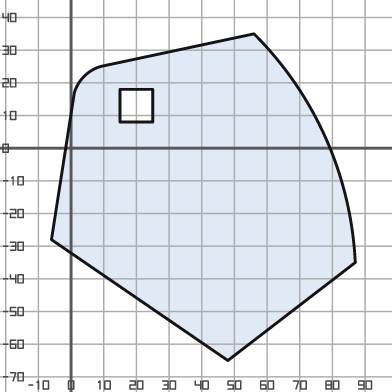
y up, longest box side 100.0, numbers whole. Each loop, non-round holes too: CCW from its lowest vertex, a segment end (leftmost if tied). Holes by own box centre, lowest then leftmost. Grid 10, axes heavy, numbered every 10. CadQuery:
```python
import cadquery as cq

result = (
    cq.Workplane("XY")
    .moveTo(48.0, -65.0)
    .lineTo(87.0, -35.0)
    .threePointArc((78.0, 3.0), (56.0, 35.0))
    .lineTo(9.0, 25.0)
    .threePointArc((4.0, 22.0), (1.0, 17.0))
    .lineTo(-6.0, -28.0)
    .close()
    .moveTo(15.0, 8.0)
    .lineTo(25.0, 8.0)
    .lineTo(25.0, 18.0)
    .lineTo(15.0, 18.0)
    .close()
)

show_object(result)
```